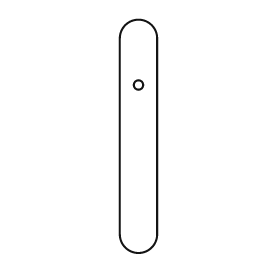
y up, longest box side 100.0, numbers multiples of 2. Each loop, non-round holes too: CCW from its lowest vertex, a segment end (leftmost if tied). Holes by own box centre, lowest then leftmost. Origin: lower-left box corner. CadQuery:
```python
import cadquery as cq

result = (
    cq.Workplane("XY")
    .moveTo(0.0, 8.0)
    .threePointArc((8.0, 0.0), (16.0, 8.0))
    .lineTo(16.0, 92.0)
    .threePointArc((8.0, 100.0), (0.0, 92.0))
    .close()
    .moveTo(8.0, 72.0)
    .circle(2.0)
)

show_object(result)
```